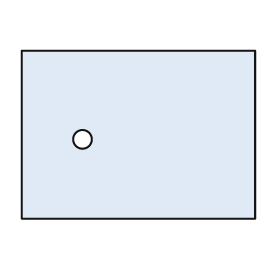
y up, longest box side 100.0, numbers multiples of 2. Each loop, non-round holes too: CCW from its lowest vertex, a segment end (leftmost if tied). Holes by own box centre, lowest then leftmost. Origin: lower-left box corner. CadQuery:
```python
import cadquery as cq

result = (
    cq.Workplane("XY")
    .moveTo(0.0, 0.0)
    .lineTo(100.0, 0.0)
    .lineTo(100.0, 72.0)
    .lineTo(0.0, 72.0)
    .close()
    .moveTo(26.0, 34.0)
    .circle(4.0)
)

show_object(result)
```